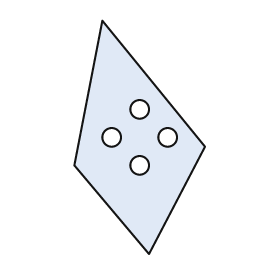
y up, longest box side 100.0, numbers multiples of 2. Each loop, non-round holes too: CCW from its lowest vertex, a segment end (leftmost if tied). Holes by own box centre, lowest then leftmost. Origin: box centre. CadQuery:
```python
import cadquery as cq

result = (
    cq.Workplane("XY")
    .moveTo(4.0, -50.0)
    .lineTo(28.0, -4.0)
    .lineTo(-16.0, 50.0)
    .lineTo(-28.0, -12.0)
    .close()
    .moveTo(0.0, -12.0)
    .circle(4.0)
    .moveTo(-12.0, 0.0)
    .circle(4.0)
    .moveTo(12.0, 0.0)
    .circle(4.0)
    .moveTo(0.0, 12.0)
    .circle(4.0)
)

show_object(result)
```